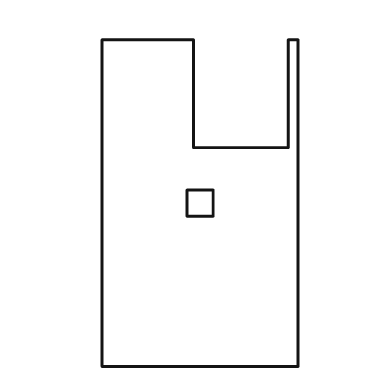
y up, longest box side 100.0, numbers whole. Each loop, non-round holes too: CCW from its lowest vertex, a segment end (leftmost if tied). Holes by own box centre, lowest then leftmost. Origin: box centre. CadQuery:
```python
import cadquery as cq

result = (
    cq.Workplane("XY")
    .moveTo(-30.0, -50.0)
    .lineTo(30.0, -50.0)
    .lineTo(30.0, 50.0)
    .lineTo(27.0, 50.0)
    .lineTo(27.0, 17.0)
    .lineTo(-2.0, 17.0)
    .lineTo(-2.0, 50.0)
    .lineTo(-30.0, 50.0)
    .close()
    .moveTo(-4.0, -4.0)
    .lineTo(4.0, -4.0)
    .lineTo(4.0, 4.0)
    .lineTo(-4.0, 4.0)
    .close()
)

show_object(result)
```